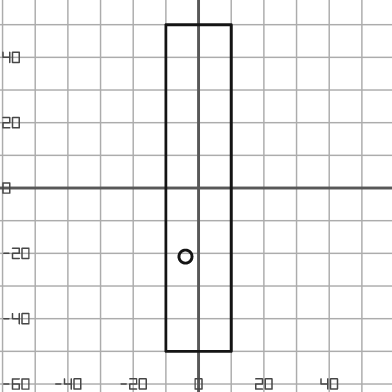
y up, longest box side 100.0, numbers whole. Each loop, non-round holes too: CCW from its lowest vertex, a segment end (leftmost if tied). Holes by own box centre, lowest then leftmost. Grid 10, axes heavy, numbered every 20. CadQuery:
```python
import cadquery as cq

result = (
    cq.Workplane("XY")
    .moveTo(-10.0, -50.0)
    .lineTo(10.0, -50.0)
    .lineTo(10.0, 50.0)
    .lineTo(-10.0, 50.0)
    .close()
    .moveTo(-4.0, -21.0)
    .circle(2.0)
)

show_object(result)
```